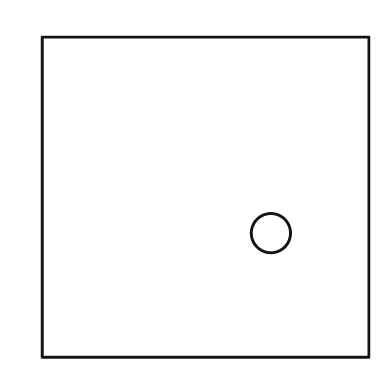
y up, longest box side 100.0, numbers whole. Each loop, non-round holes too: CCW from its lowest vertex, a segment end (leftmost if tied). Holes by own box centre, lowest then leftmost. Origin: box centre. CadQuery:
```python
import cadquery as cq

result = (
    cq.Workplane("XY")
    .moveTo(-50.0, -49.0)
    .lineTo(50.0, -49.0)
    .lineTo(50.0, 49.0)
    .lineTo(-50.0, 49.0)
    .close()
    .moveTo(20.0, -11.0)
    .circle(6.0)
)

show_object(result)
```